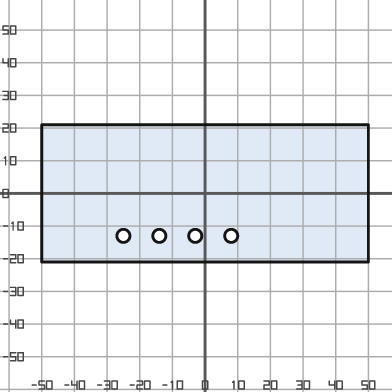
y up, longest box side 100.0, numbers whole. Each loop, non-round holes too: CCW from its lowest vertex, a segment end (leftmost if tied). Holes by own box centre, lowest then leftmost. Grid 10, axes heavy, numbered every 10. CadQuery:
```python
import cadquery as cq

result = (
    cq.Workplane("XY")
    .moveTo(-50.0, -21.0)
    .lineTo(50.0, -21.0)
    .lineTo(50.0, 21.0)
    .lineTo(-50.0, 21.0)
    .close()
    .moveTo(-25.0, -13.0)
    .circle(2.0)
    .moveTo(-14.0, -13.0)
    .circle(2.0)
    .moveTo(-3.0, -13.0)
    .circle(2.0)
    .moveTo(8.0, -13.0)
    .circle(2.0)
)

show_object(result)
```